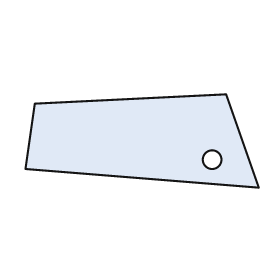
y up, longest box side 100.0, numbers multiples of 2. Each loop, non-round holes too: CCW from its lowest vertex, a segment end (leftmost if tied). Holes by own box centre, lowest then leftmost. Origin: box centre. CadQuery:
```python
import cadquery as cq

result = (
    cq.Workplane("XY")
    .moveTo(50.0, -20.0)
    .lineTo(36.0, 20.0)
    .lineTo(-46.0, 16.0)
    .lineTo(-50.0, -12.0)
    .close()
    .moveTo(30.0, -8.0)
    .circle(4.0)
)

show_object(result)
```